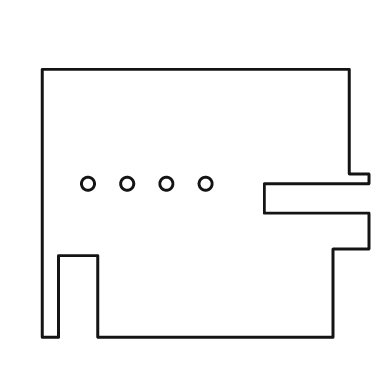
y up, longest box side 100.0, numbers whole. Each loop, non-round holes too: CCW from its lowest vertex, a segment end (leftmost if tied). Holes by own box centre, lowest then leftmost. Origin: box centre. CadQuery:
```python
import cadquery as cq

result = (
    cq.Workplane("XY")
    .moveTo(-50.0, -41.0)
    .lineTo(-45.0, -41.0)
    .lineTo(-45.0, -16.0)
    .lineTo(-33.0, -16.0)
    .lineTo(-33.0, -41.0)
    .lineTo(39.0, -41.0)
    .lineTo(39.0, -14.0)
    .lineTo(50.0, -14.0)
    .lineTo(50.0, -3.0)
    .lineTo(18.0, -3.0)
    .lineTo(18.0, 6.0)
    .lineTo(50.0, 6.0)
    .lineTo(50.0, 9.0)
    .lineTo(44.0, 9.0)
    .lineTo(44.0, 41.0)
    .lineTo(-50.0, 41.0)
    .close()
    .moveTo(-36.0, 6.0)
    .circle(2.0)
    .moveTo(-24.0, 6.0)
    .circle(2.0)
    .moveTo(-12.0, 6.0)
    .circle(2.0)
    .moveTo(0.0, 6.0)
    .circle(2.0)
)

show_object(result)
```